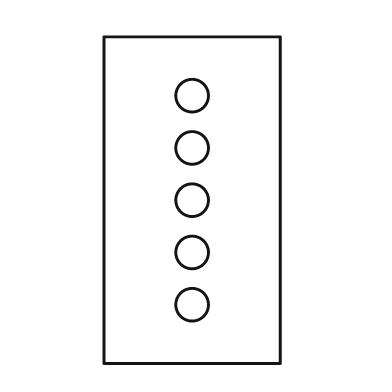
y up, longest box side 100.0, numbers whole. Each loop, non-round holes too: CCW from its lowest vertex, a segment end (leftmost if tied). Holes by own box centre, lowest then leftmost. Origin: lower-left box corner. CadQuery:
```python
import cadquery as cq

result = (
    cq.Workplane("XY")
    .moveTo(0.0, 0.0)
    .lineTo(54.0, 0.0)
    .lineTo(54.0, 100.0)
    .lineTo(0.0, 100.0)
    .close()
    .moveTo(27.0, 18.0)
    .circle(5.0)
    .moveTo(27.0, 34.0)
    .circle(5.0)
    .moveTo(27.0, 50.0)
    .circle(5.0)
    .moveTo(27.0, 66.0)
    .circle(5.0)
    .moveTo(27.0, 82.0)
    .circle(5.0)
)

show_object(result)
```